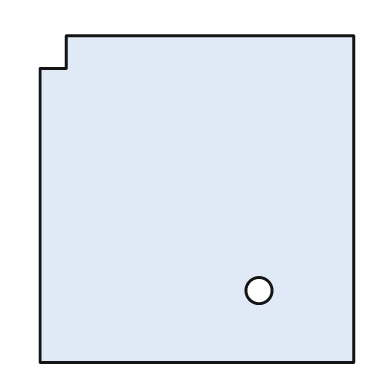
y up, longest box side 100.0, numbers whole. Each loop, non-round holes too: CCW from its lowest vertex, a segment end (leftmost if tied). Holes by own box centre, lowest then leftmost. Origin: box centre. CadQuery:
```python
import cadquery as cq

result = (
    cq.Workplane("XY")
    .moveTo(-48.0, -50.0)
    .lineTo(48.0, -50.0)
    .lineTo(48.0, 50.0)
    .lineTo(-40.0, 50.0)
    .lineTo(-40.0, 40.0)
    .lineTo(-48.0, 40.0)
    .close()
    .moveTo(19.0, -28.0)
    .circle(4.0)
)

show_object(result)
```